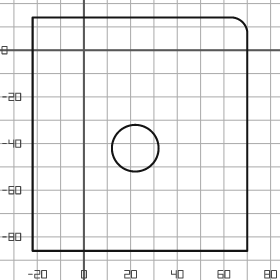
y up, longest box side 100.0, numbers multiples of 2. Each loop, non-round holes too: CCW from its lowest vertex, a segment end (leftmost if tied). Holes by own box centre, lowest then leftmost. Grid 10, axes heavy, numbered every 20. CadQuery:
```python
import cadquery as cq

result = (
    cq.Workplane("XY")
    .moveTo(-22.0, -86.0)
    .lineTo(70.0, -86.0)
    .lineTo(70.0, 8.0)
    .threePointArc((68.0, 12.0), (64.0, 14.0))
    .lineTo(-22.0, 14.0)
    .close()
    .moveTo(22.0, -42.0)
    .circle(10.0)
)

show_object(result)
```